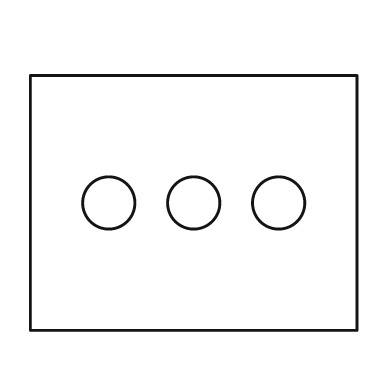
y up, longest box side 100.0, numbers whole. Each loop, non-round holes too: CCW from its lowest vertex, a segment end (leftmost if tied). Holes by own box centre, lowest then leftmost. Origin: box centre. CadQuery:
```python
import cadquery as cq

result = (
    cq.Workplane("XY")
    .moveTo(-50.0, -39.0)
    .lineTo(50.0, -39.0)
    .lineTo(50.0, 39.0)
    .lineTo(-50.0, 39.0)
    .close()
    .moveTo(-26.0, 0.0)
    .circle(8.0)
    .moveTo(0.0, 0.0)
    .circle(8.0)
    .moveTo(26.0, 0.0)
    .circle(8.0)
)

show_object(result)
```